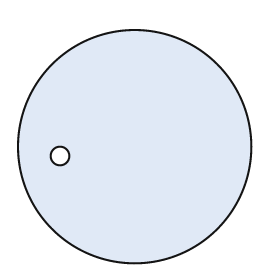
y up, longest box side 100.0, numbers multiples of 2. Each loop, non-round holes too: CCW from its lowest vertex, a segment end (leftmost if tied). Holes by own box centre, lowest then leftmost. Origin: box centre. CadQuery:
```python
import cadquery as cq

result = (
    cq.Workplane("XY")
    .moveTo(0.0, 0.0)
    .circle(50.0)
    .moveTo(-32.0, -4.0)
    .circle(4.0)
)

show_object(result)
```